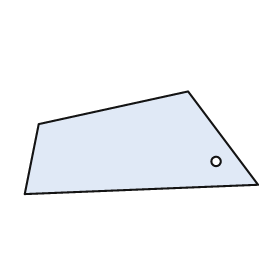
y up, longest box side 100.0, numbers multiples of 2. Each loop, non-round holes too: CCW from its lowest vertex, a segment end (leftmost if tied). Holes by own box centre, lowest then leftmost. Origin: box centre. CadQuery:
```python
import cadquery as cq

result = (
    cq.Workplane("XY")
    .moveTo(-50.0, -22.0)
    .lineTo(50.0, -18.0)
    .lineTo(20.0, 22.0)
    .lineTo(-44.0, 8.0)
    .close()
    .moveTo(32.0, -8.0)
    .circle(2.0)
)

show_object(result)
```